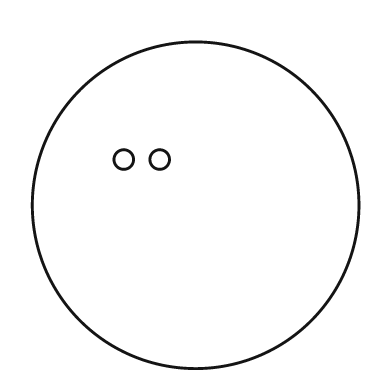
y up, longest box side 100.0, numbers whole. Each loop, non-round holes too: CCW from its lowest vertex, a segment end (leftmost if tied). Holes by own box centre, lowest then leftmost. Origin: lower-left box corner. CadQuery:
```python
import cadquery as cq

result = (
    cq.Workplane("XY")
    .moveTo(50.0, 50.0)
    .circle(50.0)
    .moveTo(28.0, 64.0)
    .circle(3.0)
    .moveTo(39.0, 64.0)
    .circle(3.0)
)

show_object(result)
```